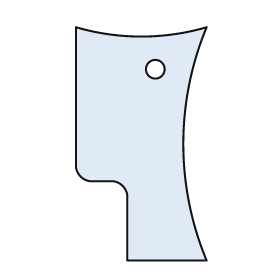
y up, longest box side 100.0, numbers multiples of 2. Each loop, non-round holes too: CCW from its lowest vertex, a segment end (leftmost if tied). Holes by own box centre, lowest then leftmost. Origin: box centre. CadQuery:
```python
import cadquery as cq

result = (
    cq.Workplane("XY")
    .moveTo(-6.0, -50.0)
    .lineTo(28.0, -50.0)
    .threePointArc((18.0, 0.0), (28.0, 50.0))
    .threePointArc((0.0, 46.0), (-28.0, 50.0))
    .lineTo(-28.0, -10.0)
    .threePointArc((-26.0, -14.0), (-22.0, -16.0))
    .lineTo(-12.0, -16.0)
    .threePointArc((-8.0, -18.0), (-6.0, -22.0))
    .close()
    .moveTo(6.0, 32.0)
    .circle(4.0)
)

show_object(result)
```